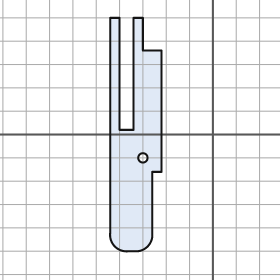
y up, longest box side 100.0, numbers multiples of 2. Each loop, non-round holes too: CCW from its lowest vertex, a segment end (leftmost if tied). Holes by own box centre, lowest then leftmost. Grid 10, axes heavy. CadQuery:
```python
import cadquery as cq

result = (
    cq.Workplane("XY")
    .moveTo(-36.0, -50.0)
    .lineTo(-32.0, -50.0)
    .threePointArc((-28.0, -48.0), (-26.0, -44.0))
    .lineTo(-26.0, -16.0)
    .lineTo(-22.0, -16.0)
    .lineTo(-22.0, 36.0)
    .lineTo(-30.0, 36.0)
    .lineTo(-30.0, 50.0)
    .lineTo(-34.0, 50.0)
    .lineTo(-34.0, 2.0)
    .lineTo(-40.0, 2.0)
    .lineTo(-40.0, 50.0)
    .lineTo(-44.0, 50.0)
    .lineTo(-44.0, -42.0)
    .threePointArc((-42.0, -48.0), (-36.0, -50.0))
    .close()
    .moveTo(-30.0, -10.0)
    .circle(2.0)
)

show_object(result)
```